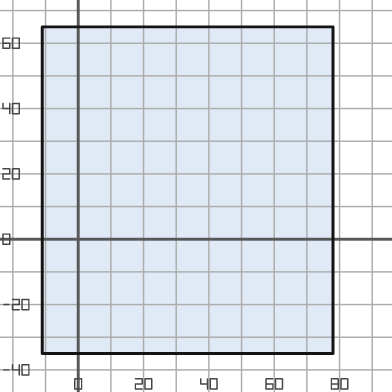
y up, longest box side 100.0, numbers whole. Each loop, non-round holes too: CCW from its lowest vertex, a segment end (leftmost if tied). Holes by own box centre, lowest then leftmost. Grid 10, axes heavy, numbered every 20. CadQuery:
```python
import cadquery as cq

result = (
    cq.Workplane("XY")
    .moveTo(-11.0, -35.0)
    .lineTo(78.0, -35.0)
    .lineTo(78.0, 65.0)
    .lineTo(-11.0, 65.0)
    .close()
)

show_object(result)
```